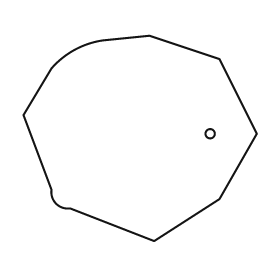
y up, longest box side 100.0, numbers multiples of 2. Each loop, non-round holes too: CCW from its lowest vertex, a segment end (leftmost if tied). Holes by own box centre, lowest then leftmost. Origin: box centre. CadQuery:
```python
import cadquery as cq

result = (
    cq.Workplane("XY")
    .moveTo(6.0, -44.0)
    .lineTo(34.0, -26.0)
    .lineTo(50.0, 2.0)
    .lineTo(34.0, 34.0)
    .lineTo(4.0, 44.0)
    .lineTo(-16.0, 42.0)
    .threePointArc((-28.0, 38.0), (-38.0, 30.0))
    .lineTo(-50.0, 10.0)
    .lineTo(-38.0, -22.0)
    .threePointArc((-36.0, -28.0), (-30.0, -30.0))
    .close()
    .moveTo(30.0, 2.0)
    .circle(2.0)
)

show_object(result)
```